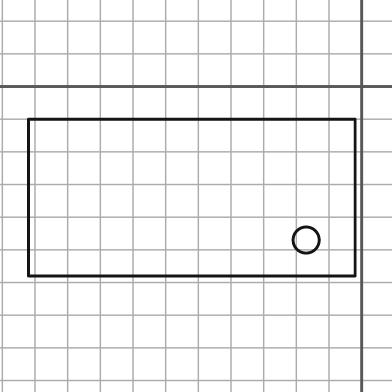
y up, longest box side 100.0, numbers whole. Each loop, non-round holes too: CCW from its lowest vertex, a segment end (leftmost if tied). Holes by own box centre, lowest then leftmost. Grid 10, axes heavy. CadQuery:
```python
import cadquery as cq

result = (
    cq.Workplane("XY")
    .moveTo(-102.0, -58.0)
    .lineTo(-2.0, -58.0)
    .lineTo(-2.0, -10.0)
    .lineTo(-102.0, -10.0)
    .close()
    .moveTo(-17.0, -47.0)
    .circle(4.0)
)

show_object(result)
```